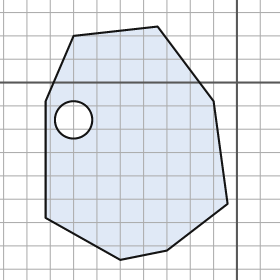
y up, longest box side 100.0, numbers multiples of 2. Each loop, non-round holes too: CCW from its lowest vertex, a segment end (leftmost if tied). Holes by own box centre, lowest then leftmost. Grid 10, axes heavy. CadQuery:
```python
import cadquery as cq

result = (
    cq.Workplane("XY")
    .moveTo(-50.0, -76.0)
    .lineTo(-30.0, -72.0)
    .lineTo(-4.0, -52.0)
    .lineTo(-10.0, -8.0)
    .lineTo(-34.0, 24.0)
    .lineTo(-70.0, 20.0)
    .lineTo(-82.0, -8.0)
    .lineTo(-82.0, -58.0)
    .close()
    .moveTo(-70.0, -16.0)
    .circle(8.0)
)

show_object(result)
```